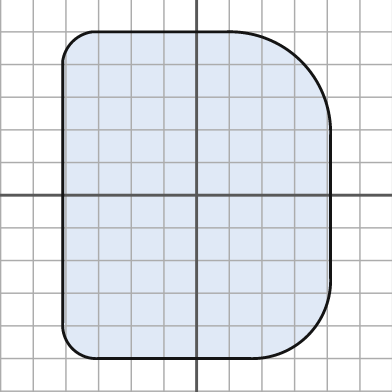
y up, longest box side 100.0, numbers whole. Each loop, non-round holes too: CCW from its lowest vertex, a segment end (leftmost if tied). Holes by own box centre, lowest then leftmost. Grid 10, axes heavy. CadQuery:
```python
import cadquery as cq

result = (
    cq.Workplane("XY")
    .moveTo(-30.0, -50.0)
    .lineTo(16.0, -50.0)
    .threePointArc((34.0, -43.0), (41.0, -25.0))
    .lineTo(41.0, 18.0)
    .threePointArc((32.0, 41.0), (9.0, 50.0))
    .lineTo(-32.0, 50.0)
    .threePointArc((-38.0, 47.0), (-41.0, 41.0))
    .lineTo(-41.0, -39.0)
    .threePointArc((-38.0, -47.0), (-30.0, -50.0))
    .close()
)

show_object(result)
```